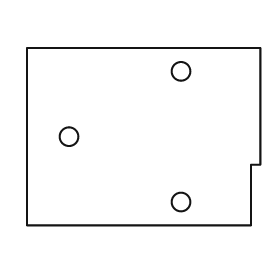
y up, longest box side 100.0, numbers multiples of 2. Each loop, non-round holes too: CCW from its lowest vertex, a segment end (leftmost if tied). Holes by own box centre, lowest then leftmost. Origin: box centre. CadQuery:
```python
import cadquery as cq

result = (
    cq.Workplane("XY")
    .moveTo(-50.0, -38.0)
    .lineTo(46.0, -38.0)
    .lineTo(46.0, -12.0)
    .lineTo(50.0, -12.0)
    .lineTo(50.0, 38.0)
    .lineTo(-50.0, 38.0)
    .close()
    .moveTo(16.0, -28.0)
    .circle(4.0)
    .moveTo(-32.0, 0.0)
    .circle(4.0)
    .moveTo(16.0, 28.0)
    .circle(4.0)
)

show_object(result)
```